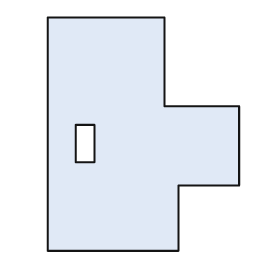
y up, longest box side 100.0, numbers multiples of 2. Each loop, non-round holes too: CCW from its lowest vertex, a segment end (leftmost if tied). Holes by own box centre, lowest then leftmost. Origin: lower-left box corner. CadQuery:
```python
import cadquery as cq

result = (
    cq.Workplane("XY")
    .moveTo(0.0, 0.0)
    .lineTo(56.0, 0.0)
    .lineTo(56.0, 28.0)
    .lineTo(82.0, 28.0)
    .lineTo(82.0, 62.0)
    .lineTo(50.0, 62.0)
    .lineTo(50.0, 100.0)
    .lineTo(0.0, 100.0)
    .close()
    .moveTo(12.0, 38.0)
    .lineTo(20.0, 38.0)
    .lineTo(20.0, 54.0)
    .lineTo(12.0, 54.0)
    .close()
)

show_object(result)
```